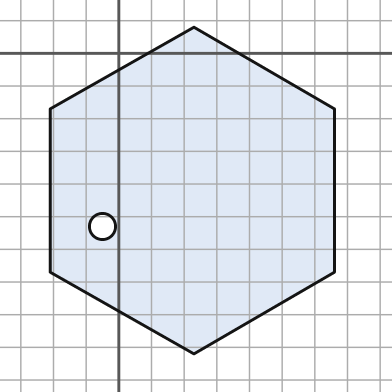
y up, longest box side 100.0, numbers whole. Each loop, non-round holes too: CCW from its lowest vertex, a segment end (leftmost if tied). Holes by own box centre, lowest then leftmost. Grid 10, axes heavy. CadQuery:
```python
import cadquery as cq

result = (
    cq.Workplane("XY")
    .moveTo(23.0, -92.0)
    .lineTo(66.0, -67.0)
    .lineTo(66.0, -17.0)
    .lineTo(23.0, 8.0)
    .lineTo(-21.0, -17.0)
    .lineTo(-21.0, -67.0)
    .close()
    .moveTo(-5.0, -53.0)
    .circle(4.0)
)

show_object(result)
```